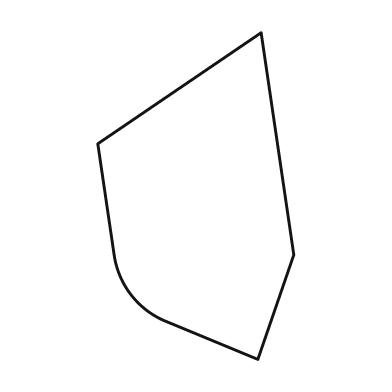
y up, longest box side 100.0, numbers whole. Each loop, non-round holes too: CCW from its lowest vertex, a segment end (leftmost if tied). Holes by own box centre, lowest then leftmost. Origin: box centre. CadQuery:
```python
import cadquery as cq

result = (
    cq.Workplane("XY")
    .moveTo(19.0, -50.0)
    .lineTo(30.0, -18.0)
    .lineTo(20.0, 50.0)
    .lineTo(-30.0, 16.0)
    .lineTo(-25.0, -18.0)
    .threePointArc((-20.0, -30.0), (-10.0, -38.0))
    .close()
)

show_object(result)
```